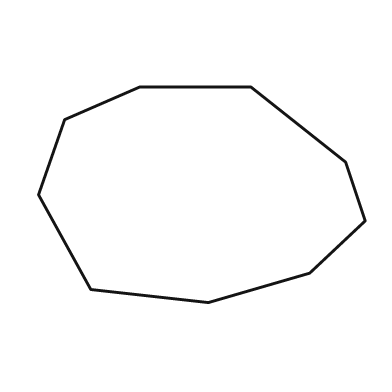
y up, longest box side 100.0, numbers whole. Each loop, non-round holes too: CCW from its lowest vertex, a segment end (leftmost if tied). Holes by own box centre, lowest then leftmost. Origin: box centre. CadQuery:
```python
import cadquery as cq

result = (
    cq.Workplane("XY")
    .moveTo(2.0, -33.0)
    .lineTo(33.0, -24.0)
    .lineTo(50.0, -8.0)
    .lineTo(44.0, 10.0)
    .lineTo(15.0, 33.0)
    .lineTo(-19.0, 33.0)
    .lineTo(-42.0, 23.0)
    .lineTo(-50.0, 0.0)
    .lineTo(-34.0, -29.0)
    .close()
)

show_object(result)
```